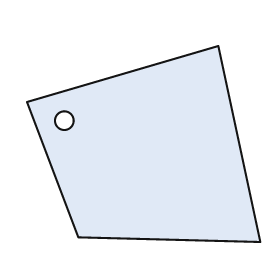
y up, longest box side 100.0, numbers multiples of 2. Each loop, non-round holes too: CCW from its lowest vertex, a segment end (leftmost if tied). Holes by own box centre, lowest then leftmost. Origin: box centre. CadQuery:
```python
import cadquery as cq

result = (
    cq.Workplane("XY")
    .moveTo(50.0, -42.0)
    .lineTo(32.0, 42.0)
    .lineTo(-50.0, 18.0)
    .lineTo(-28.0, -40.0)
    .close()
    .moveTo(-34.0, 10.0)
    .circle(4.0)
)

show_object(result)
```